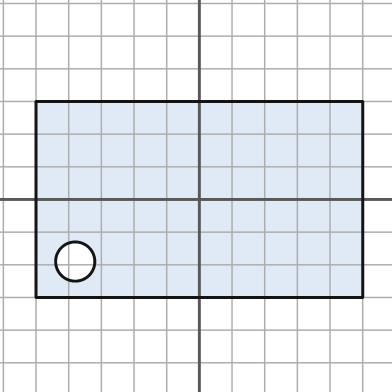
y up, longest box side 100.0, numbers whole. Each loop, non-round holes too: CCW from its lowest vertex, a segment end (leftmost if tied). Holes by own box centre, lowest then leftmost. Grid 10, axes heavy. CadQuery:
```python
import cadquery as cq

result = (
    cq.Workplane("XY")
    .moveTo(-50.0, -30.0)
    .lineTo(50.0, -30.0)
    .lineTo(50.0, 30.0)
    .lineTo(-50.0, 30.0)
    .close()
    .moveTo(-38.0, -19.0)
    .circle(6.0)
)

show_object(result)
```